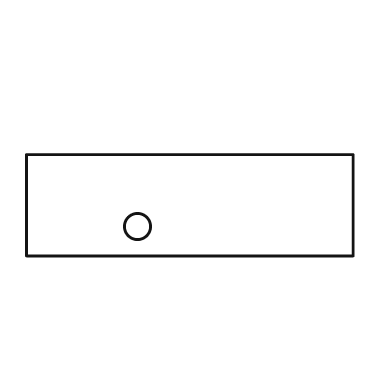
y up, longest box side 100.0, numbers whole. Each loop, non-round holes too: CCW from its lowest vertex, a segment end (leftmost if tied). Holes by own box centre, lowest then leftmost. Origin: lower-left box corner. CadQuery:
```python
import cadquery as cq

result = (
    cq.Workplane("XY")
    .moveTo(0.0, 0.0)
    .lineTo(100.0, 0.0)
    .lineTo(100.0, 31.0)
    .lineTo(0.0, 31.0)
    .close()
    .moveTo(34.0, 9.0)
    .circle(4.0)
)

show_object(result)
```